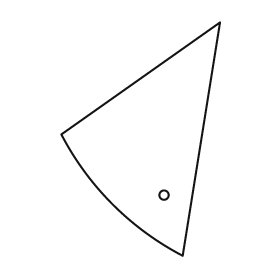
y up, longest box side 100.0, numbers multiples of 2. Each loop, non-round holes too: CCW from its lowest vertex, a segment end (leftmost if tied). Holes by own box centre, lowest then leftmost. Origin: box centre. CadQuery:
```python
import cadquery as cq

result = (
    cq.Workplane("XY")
    .moveTo(18.0, -50.0)
    .lineTo(34.0, 50.0)
    .lineTo(-34.0, 2.0)
    .threePointArc((-12.0, -28.0), (18.0, -50.0))
    .close()
    .moveTo(10.0, -24.0)
    .circle(2.0)
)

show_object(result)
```